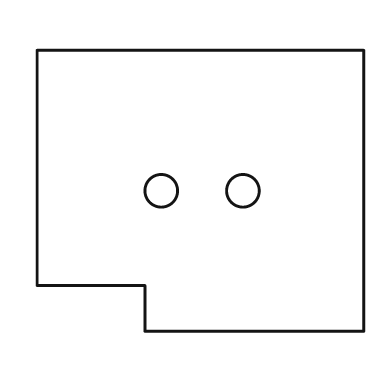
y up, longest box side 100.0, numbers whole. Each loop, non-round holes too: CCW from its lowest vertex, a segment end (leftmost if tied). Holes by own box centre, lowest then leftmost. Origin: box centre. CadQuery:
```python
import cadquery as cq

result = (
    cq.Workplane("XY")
    .moveTo(-17.0, -43.0)
    .lineTo(50.0, -43.0)
    .lineTo(50.0, 43.0)
    .lineTo(-50.0, 43.0)
    .lineTo(-50.0, -29.0)
    .lineTo(-17.0, -29.0)
    .close()
    .moveTo(-12.0, 0.0)
    .circle(5.0)
    .moveTo(13.0, 0.0)
    .circle(5.0)
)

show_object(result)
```